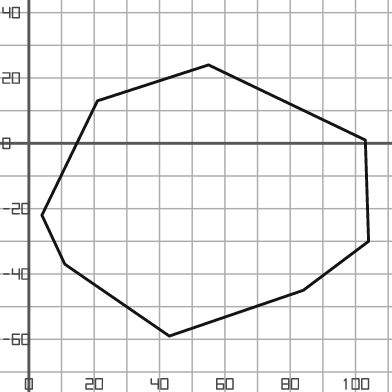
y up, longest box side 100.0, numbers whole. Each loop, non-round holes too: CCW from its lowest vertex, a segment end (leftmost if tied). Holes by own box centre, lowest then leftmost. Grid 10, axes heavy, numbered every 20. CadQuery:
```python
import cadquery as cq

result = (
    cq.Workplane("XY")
    .moveTo(43.0, -59.0)
    .lineTo(84.0, -45.0)
    .lineTo(104.0, -30.0)
    .lineTo(103.0, 1.0)
    .lineTo(55.0, 24.0)
    .lineTo(21.0, 13.0)
    .lineTo(4.0, -22.0)
    .lineTo(11.0, -37.0)
    .close()
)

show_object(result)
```